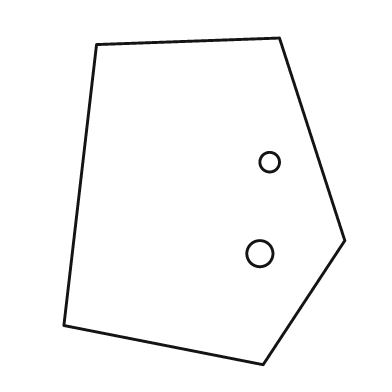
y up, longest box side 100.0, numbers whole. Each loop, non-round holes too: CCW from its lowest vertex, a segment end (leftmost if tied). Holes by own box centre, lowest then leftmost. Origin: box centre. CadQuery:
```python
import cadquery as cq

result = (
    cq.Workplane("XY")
    .moveTo(18.0, -50.0)
    .lineTo(43.0, -12.0)
    .lineTo(23.0, 50.0)
    .lineTo(-33.0, 48.0)
    .lineTo(-43.0, -38.0)
    .close()
    .moveTo(17.0, -16.0)
    .circle(4.0)
    .moveTo(20.0, 12.0)
    .circle(3.0)
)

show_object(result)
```